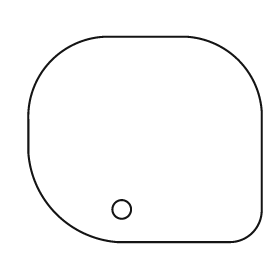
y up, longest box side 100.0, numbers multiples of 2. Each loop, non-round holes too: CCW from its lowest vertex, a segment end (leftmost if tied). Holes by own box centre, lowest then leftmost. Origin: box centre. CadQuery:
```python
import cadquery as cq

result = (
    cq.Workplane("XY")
    .moveTo(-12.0, -44.0)
    .lineTo(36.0, -44.0)
    .threePointArc((46.0, -40.0), (50.0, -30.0))
    .lineTo(50.0, 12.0)
    .threePointArc((40.0, 34.0), (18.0, 44.0))
    .lineTo(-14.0, 44.0)
    .threePointArc((-40.0, 34.0), (-50.0, 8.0))
    .lineTo(-50.0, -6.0)
    .threePointArc((-38.0, -32.0), (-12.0, -44.0))
    .close()
    .moveTo(-10.0, -30.0)
    .circle(4.0)
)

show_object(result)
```